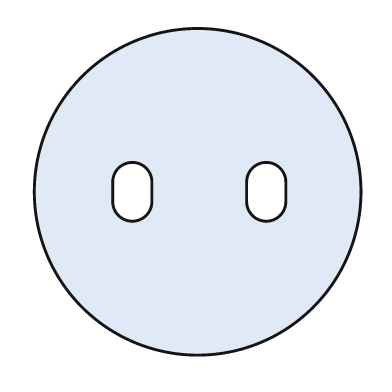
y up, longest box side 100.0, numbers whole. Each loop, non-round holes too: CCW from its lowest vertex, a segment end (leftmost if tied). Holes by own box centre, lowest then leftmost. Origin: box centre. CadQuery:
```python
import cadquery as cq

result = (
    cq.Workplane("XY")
    .moveTo(0.0, 0.0)
    .circle(50.0)
    .moveTo(-26.0, -3.0)
    .threePointArc((-20.0, -9.0), (-14.0, -3.0))
    .lineTo(-14.0, 3.0)
    .threePointArc((-20.0, 9.0), (-26.0, 3.0))
    .close()
    .moveTo(15.0, -3.0)
    .threePointArc((21.0, -9.0), (27.0, -3.0))
    .lineTo(27.0, 3.0)
    .threePointArc((21.0, 9.0), (15.0, 3.0))
    .close()
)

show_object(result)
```